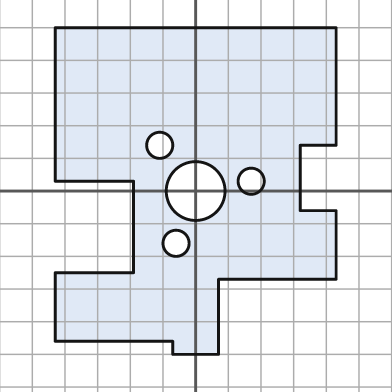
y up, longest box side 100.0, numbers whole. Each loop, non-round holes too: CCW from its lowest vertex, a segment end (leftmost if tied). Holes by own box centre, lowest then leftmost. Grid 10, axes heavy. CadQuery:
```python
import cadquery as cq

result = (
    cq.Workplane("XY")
    .moveTo(-7.0, -50.0)
    .lineTo(7.0, -50.0)
    .lineTo(7.0, -27.0)
    .lineTo(43.0, -27.0)
    .lineTo(43.0, -6.0)
    .lineTo(32.0, -6.0)
    .lineTo(32.0, 14.0)
    .lineTo(43.0, 14.0)
    .lineTo(43.0, 50.0)
    .lineTo(-43.0, 50.0)
    .lineTo(-43.0, 3.0)
    .lineTo(-19.0, 3.0)
    .lineTo(-19.0, -25.0)
    .lineTo(-43.0, -25.0)
    .lineTo(-43.0, -46.0)
    .lineTo(-7.0, -46.0)
    .close()
    .moveTo(-6.0, -16.0)
    .circle(4.0)
    .moveTo(0.0, 0.0)
    .circle(9.0)
    .moveTo(17.0, 3.0)
    .circle(4.0)
    .moveTo(-11.0, 14.0)
    .circle(4.0)
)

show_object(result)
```